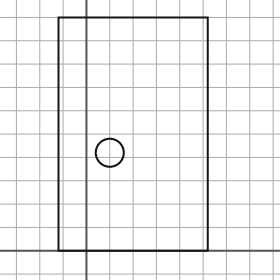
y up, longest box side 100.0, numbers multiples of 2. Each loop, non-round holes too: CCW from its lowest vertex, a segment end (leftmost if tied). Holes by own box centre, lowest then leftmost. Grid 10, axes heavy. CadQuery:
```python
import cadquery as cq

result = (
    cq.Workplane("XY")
    .moveTo(-12.0, 0.0)
    .lineTo(52.0, 0.0)
    .lineTo(52.0, 100.0)
    .lineTo(-12.0, 100.0)
    .close()
    .moveTo(10.0, 42.0)
    .circle(6.0)
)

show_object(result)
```